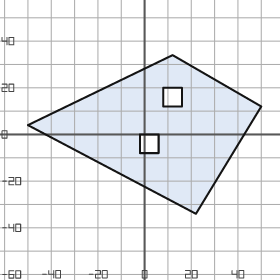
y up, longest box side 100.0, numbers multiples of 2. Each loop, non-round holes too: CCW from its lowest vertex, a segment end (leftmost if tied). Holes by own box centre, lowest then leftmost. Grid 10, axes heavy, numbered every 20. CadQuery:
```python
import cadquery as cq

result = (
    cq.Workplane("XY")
    .moveTo(22.0, -34.0)
    .lineTo(50.0, 12.0)
    .lineTo(12.0, 34.0)
    .lineTo(-50.0, 4.0)
    .close()
    .moveTo(-2.0, -8.0)
    .lineTo(6.0, -8.0)
    .lineTo(6.0, 0.0)
    .lineTo(-2.0, 0.0)
    .close()
    .moveTo(8.0, 12.0)
    .lineTo(16.0, 12.0)
    .lineTo(16.0, 20.0)
    .lineTo(8.0, 20.0)
    .close()
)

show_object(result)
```